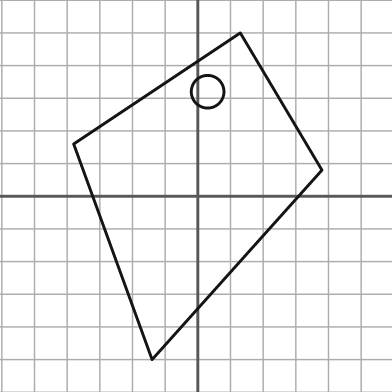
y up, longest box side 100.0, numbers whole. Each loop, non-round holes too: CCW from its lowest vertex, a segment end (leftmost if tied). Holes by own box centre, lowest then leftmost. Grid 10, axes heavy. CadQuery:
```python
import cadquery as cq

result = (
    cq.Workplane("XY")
    .moveTo(-14.0, -50.0)
    .lineTo(38.0, 8.0)
    .lineTo(13.0, 50.0)
    .lineTo(-38.0, 16.0)
    .close()
    .moveTo(3.0, 32.0)
    .circle(5.0)
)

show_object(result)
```